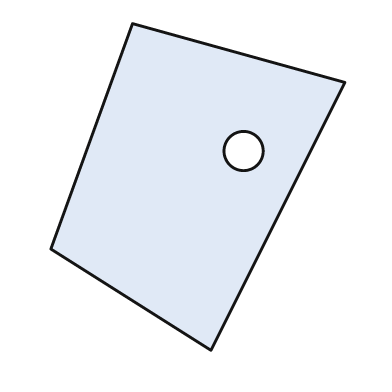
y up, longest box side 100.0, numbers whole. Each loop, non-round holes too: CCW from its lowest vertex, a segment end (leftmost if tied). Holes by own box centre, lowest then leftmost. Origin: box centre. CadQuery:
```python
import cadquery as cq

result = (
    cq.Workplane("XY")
    .moveTo(4.0, -50.0)
    .lineTo(45.0, 32.0)
    .lineTo(-20.0, 50.0)
    .lineTo(-45.0, -19.0)
    .close()
    .moveTo(14.0, 11.0)
    .circle(6.0)
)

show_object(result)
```